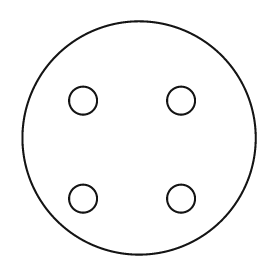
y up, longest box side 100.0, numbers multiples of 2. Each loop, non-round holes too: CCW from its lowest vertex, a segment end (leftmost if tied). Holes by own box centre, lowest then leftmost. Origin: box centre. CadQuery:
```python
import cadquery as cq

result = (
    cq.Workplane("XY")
    .moveTo(0.0, 0.0)
    .circle(50.0)
    .moveTo(-24.0, -26.0)
    .circle(6.0)
    .moveTo(18.0, -26.0)
    .circle(6.0)
    .moveTo(-24.0, 16.0)
    .circle(6.0)
    .moveTo(18.0, 16.0)
    .circle(6.0)
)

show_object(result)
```